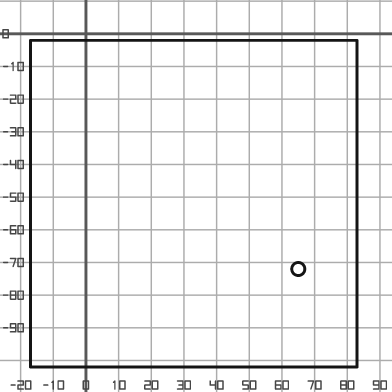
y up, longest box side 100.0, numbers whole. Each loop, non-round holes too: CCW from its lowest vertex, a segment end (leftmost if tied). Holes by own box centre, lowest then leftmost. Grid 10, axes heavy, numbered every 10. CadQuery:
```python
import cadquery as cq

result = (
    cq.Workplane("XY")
    .moveTo(-17.0, -102.0)
    .lineTo(83.0, -102.0)
    .lineTo(83.0, -2.0)
    .lineTo(-17.0, -2.0)
    .close()
    .moveTo(65.0, -72.0)
    .circle(2.0)
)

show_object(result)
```